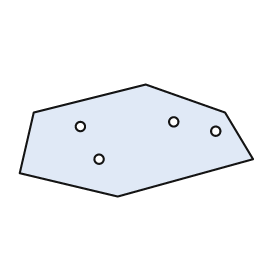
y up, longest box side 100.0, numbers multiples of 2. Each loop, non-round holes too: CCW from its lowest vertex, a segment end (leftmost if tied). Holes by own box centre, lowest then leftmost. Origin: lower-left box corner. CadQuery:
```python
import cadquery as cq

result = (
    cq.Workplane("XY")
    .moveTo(42.0, 0.0)
    .lineTo(100.0, 16.0)
    .lineTo(88.0, 36.0)
    .lineTo(54.0, 48.0)
    .lineTo(6.0, 36.0)
    .lineTo(0.0, 10.0)
    .close()
    .moveTo(34.0, 16.0)
    .circle(2.0)
    .moveTo(84.0, 28.0)
    .circle(2.0)
    .moveTo(26.0, 30.0)
    .circle(2.0)
    .moveTo(66.0, 32.0)
    .circle(2.0)
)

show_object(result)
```